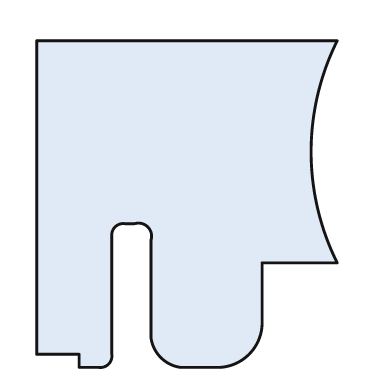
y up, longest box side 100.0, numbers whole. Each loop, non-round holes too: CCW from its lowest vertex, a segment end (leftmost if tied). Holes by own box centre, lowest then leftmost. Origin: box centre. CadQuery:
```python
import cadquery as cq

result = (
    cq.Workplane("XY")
    .moveTo(-33.0, -50.0)
    .lineTo(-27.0, -50.0)
    .threePointArc((-24.0, -49.0), (-23.0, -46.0))
    .lineTo(-23.0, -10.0)
    .threePointArc((-22.0, -7.0), (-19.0, -6.0))
    .lineTo(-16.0, -6.0)
    .threePointArc((-12.0, -7.0), (-11.0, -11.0))
    .lineTo(-11.0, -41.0)
    .threePointArc((-8.0, -47.0), (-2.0, -50.0))
    .lineTo(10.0, -50.0)
    .threePointArc((19.0, -46.0), (23.0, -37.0))
    .lineTo(23.0, -18.0)
    .lineTo(46.0, -18.0)
    .threePointArc((38.0, 16.0), (46.0, 50.0))
    .lineTo(-46.0, 50.0)
    .lineTo(-46.0, -46.0)
    .lineTo(-33.0, -46.0)
    .close()
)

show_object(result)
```